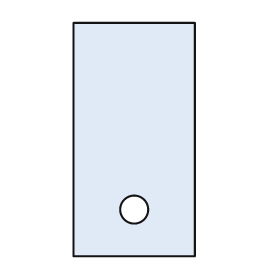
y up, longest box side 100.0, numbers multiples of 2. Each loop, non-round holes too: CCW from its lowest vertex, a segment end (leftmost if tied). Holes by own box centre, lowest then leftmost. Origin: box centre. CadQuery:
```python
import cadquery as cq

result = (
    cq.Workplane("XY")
    .moveTo(-26.0, -50.0)
    .lineTo(26.0, -50.0)
    .lineTo(26.0, 50.0)
    .lineTo(-26.0, 50.0)
    .close()
    .moveTo(0.0, -30.0)
    .circle(6.0)
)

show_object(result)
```